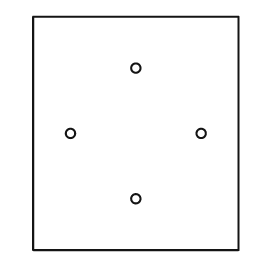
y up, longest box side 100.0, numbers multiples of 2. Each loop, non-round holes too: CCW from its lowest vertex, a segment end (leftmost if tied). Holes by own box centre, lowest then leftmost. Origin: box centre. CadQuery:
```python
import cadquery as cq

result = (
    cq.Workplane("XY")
    .moveTo(-44.0, -50.0)
    .lineTo(44.0, -50.0)
    .lineTo(44.0, 50.0)
    .lineTo(-44.0, 50.0)
    .close()
    .moveTo(0.0, -28.0)
    .circle(2.0)
    .moveTo(-28.0, 0.0)
    .circle(2.0)
    .moveTo(28.0, 0.0)
    .circle(2.0)
    .moveTo(0.0, 28.0)
    .circle(2.0)
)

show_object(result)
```